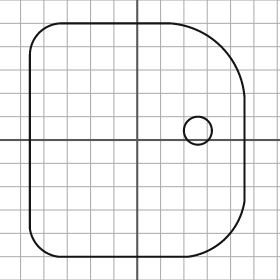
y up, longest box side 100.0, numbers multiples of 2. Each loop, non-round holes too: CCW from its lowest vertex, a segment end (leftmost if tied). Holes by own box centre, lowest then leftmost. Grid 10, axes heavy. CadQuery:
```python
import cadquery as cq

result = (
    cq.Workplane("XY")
    .moveTo(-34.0, -50.0)
    .lineTo(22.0, -50.0)
    .threePointArc((38.0, -42.0), (46.0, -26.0))
    .lineTo(46.0, 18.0)
    .threePointArc((36.0, 40.0), (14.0, 50.0))
    .lineTo(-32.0, 50.0)
    .threePointArc((-42.0, 46.0), (-46.0, 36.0))
    .lineTo(-46.0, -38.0)
    .threePointArc((-42.0, -46.0), (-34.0, -50.0))
    .close()
    .moveTo(26.0, 4.0)
    .circle(6.0)
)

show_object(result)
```